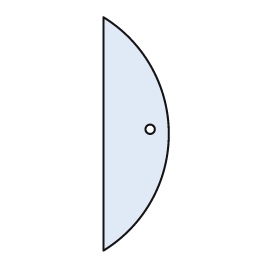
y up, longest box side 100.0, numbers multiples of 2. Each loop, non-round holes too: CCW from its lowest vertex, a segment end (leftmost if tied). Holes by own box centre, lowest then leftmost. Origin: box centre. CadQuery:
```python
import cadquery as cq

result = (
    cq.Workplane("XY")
    .moveTo(-14.0, -50.0)
    .threePointArc((14.0, 0.0), (-14.0, 50.0))
    .close()
    .moveTo(6.0, 2.0)
    .circle(2.0)
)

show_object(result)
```